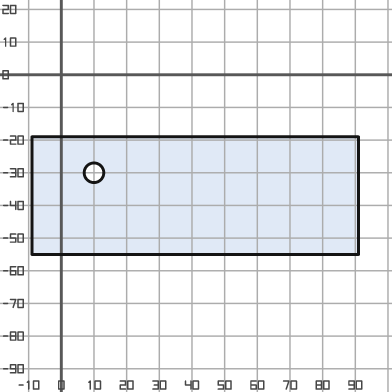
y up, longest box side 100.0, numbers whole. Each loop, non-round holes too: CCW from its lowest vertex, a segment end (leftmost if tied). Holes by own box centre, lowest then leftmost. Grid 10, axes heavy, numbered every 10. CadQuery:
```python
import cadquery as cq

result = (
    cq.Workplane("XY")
    .moveTo(-9.0, -55.0)
    .lineTo(91.0, -55.0)
    .lineTo(91.0, -19.0)
    .lineTo(-9.0, -19.0)
    .close()
    .moveTo(10.0, -30.0)
    .circle(3.0)
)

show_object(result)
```